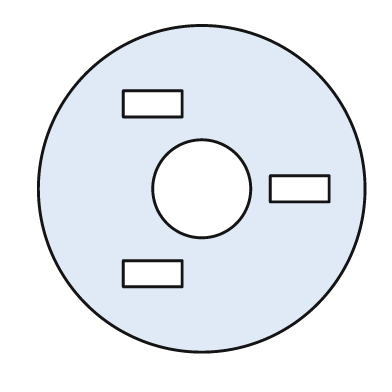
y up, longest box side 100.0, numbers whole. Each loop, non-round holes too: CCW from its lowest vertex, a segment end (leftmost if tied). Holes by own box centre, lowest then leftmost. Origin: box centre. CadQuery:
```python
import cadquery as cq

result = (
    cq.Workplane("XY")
    .moveTo(0.0, 0.0)
    .circle(50.0)
    .moveTo(-24.0, -30.0)
    .lineTo(-6.0, -30.0)
    .lineTo(-6.0, -22.0)
    .lineTo(-24.0, -22.0)
    .close()
    .moveTo(0.0, 0.0)
    .circle(15.0)
    .moveTo(21.0, -4.0)
    .lineTo(39.0, -4.0)
    .lineTo(39.0, 4.0)
    .lineTo(21.0, 4.0)
    .close()
    .moveTo(-24.0, 22.0)
    .lineTo(-6.0, 22.0)
    .lineTo(-6.0, 30.0)
    .lineTo(-24.0, 30.0)
    .close()
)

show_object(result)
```